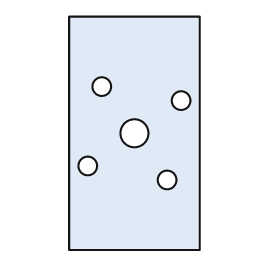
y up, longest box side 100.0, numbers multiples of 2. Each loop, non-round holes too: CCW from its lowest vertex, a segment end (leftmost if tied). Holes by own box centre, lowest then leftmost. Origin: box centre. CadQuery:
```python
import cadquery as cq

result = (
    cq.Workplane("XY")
    .moveTo(-28.0, -50.0)
    .lineTo(28.0, -50.0)
    .lineTo(28.0, 50.0)
    .lineTo(-28.0, 50.0)
    .close()
    .moveTo(14.0, -20.0)
    .circle(4.0)
    .moveTo(-20.0, -14.0)
    .circle(4.0)
    .moveTo(0.0, 0.0)
    .circle(6.0)
    .moveTo(20.0, 14.0)
    .circle(4.0)
    .moveTo(-14.0, 20.0)
    .circle(4.0)
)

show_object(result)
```